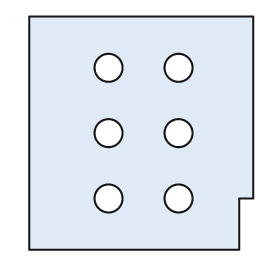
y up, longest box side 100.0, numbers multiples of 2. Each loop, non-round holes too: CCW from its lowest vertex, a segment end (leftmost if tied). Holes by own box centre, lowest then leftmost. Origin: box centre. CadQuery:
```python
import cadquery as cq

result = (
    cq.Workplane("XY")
    .moveTo(-48.0, -50.0)
    .lineTo(42.0, -50.0)
    .lineTo(42.0, -28.0)
    .lineTo(48.0, -28.0)
    .lineTo(48.0, 50.0)
    .lineTo(-48.0, 50.0)
    .close()
    .moveTo(-14.0, -28.0)
    .circle(6.0)
    .moveTo(16.0, -28.0)
    .circle(6.0)
    .moveTo(-14.0, 0.0)
    .circle(6.0)
    .moveTo(16.0, 0.0)
    .circle(6.0)
    .moveTo(-14.0, 28.0)
    .circle(6.0)
    .moveTo(16.0, 28.0)
    .circle(6.0)
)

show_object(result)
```